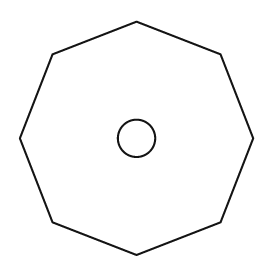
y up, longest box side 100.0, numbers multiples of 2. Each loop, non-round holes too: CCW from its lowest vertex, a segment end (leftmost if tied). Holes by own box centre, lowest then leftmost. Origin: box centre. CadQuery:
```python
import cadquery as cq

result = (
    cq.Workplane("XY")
    .moveTo(0.0, -50.0)
    .lineTo(36.0, -36.0)
    .lineTo(50.0, 0.0)
    .lineTo(36.0, 36.0)
    .lineTo(0.0, 50.0)
    .lineTo(-36.0, 36.0)
    .lineTo(-50.0, 0.0)
    .lineTo(-36.0, -36.0)
    .close()
    .moveTo(0.0, 0.0)
    .circle(8.0)
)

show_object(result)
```